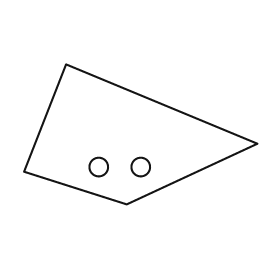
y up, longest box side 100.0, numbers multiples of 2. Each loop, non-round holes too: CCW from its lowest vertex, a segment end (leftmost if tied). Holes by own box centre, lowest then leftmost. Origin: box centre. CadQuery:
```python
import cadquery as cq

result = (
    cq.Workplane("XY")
    .moveTo(-6.0, -30.0)
    .lineTo(50.0, -4.0)
    .lineTo(-32.0, 30.0)
    .lineTo(-50.0, -16.0)
    .close()
    .moveTo(-18.0, -14.0)
    .circle(4.0)
    .moveTo(0.0, -14.0)
    .circle(4.0)
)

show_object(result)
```